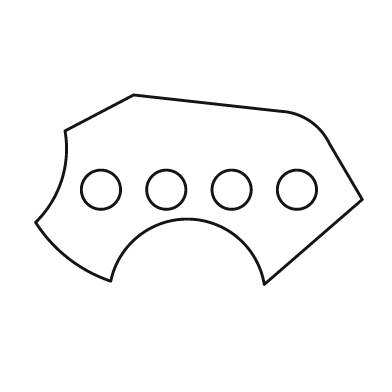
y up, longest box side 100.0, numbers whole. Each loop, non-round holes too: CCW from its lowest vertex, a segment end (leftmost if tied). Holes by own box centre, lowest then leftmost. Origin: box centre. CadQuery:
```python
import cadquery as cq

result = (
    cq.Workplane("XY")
    .moveTo(20.0, -29.0)
    .lineTo(50.0, -3.0)
    .lineTo(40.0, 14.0)
    .threePointArc((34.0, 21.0), (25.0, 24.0))
    .lineTo(-20.0, 29.0)
    .lineTo(-41.0, 18.0)
    .threePointArc((-42.0, 3.0), (-50.0, -10.0))
    .threePointArc((-40.0, -21.0), (-27.0, -28.0))
    .threePointArc((-3.0, -9.0), (20.0, -29.0))
    .close()
    .moveTo(-30.0, 0.0)
    .circle(6.0)
    .moveTo(-10.0, 0.0)
    .circle(6.0)
    .moveTo(10.0, 0.0)
    .circle(6.0)
    .moveTo(30.0, 0.0)
    .circle(6.0)
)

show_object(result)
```